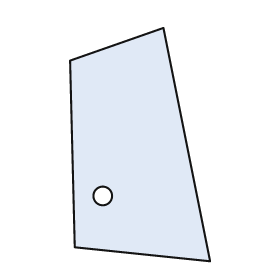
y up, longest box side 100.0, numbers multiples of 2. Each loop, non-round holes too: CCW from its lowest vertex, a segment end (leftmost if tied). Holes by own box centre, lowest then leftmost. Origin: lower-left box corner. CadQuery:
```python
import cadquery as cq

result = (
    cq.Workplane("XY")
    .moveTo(60.0, 0.0)
    .lineTo(40.0, 100.0)
    .lineTo(0.0, 86.0)
    .lineTo(2.0, 6.0)
    .close()
    .moveTo(14.0, 28.0)
    .circle(4.0)
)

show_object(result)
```